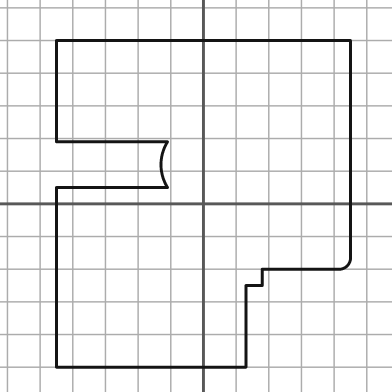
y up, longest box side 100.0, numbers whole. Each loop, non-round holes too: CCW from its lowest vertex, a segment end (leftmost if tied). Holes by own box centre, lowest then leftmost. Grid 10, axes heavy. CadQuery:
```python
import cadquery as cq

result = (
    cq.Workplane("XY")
    .moveTo(-45.0, -50.0)
    .lineTo(13.0, -50.0)
    .lineTo(13.0, -25.0)
    .lineTo(18.0, -25.0)
    .lineTo(18.0, -20.0)
    .lineTo(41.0, -20.0)
    .threePointArc((44.0, -19.0), (45.0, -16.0))
    .lineTo(45.0, 50.0)
    .lineTo(-45.0, 50.0)
    .lineTo(-45.0, 19.0)
    .lineTo(-11.0, 19.0)
    .threePointArc((-13.0, 12.0), (-11.0, 5.0))
    .lineTo(-45.0, 5.0)
    .close()
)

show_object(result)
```